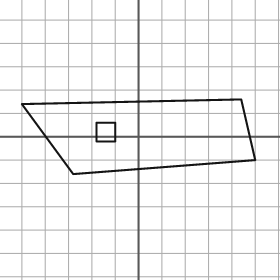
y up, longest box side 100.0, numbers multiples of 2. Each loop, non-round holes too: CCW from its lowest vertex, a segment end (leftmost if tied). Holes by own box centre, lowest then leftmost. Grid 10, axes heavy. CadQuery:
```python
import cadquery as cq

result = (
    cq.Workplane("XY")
    .moveTo(-28.0, -16.0)
    .lineTo(50.0, -10.0)
    .lineTo(44.0, 16.0)
    .lineTo(-50.0, 14.0)
    .close()
    .moveTo(-18.0, -2.0)
    .lineTo(-10.0, -2.0)
    .lineTo(-10.0, 6.0)
    .lineTo(-18.0, 6.0)
    .close()
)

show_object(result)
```